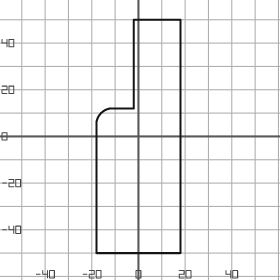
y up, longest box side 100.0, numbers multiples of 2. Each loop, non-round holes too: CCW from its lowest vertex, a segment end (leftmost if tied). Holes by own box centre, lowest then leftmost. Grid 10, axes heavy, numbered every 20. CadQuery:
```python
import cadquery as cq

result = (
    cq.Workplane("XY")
    .moveTo(-18.0, -50.0)
    .lineTo(18.0, -50.0)
    .lineTo(18.0, 50.0)
    .lineTo(-2.0, 50.0)
    .lineTo(-2.0, 12.0)
    .lineTo(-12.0, 12.0)
    .threePointArc((-16.0, 10.0), (-18.0, 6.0))
    .close()
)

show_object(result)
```